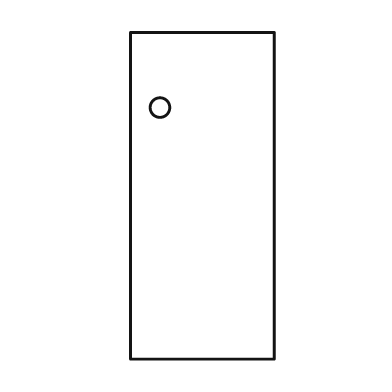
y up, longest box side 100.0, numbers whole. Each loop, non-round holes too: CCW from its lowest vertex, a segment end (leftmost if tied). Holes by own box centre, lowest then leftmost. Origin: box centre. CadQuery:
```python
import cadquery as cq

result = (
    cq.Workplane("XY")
    .moveTo(-22.0, -50.0)
    .lineTo(22.0, -50.0)
    .lineTo(22.0, 50.0)
    .lineTo(-22.0, 50.0)
    .close()
    .moveTo(-13.0, 27.0)
    .circle(3.0)
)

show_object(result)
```